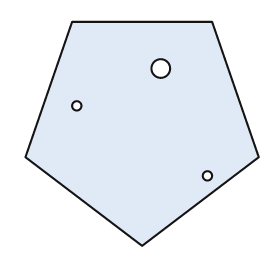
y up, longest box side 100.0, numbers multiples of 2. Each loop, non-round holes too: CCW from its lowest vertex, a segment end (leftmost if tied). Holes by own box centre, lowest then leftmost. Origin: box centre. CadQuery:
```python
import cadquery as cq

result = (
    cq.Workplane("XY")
    .moveTo(0.0, -48.0)
    .lineTo(50.0, -10.0)
    .lineTo(30.0, 48.0)
    .lineTo(-30.0, 48.0)
    .lineTo(-50.0, -10.0)
    .close()
    .moveTo(28.0, -18.0)
    .circle(2.0)
    .moveTo(-28.0, 12.0)
    .circle(2.0)
    .moveTo(8.0, 28.0)
    .circle(4.0)
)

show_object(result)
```